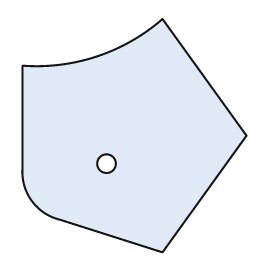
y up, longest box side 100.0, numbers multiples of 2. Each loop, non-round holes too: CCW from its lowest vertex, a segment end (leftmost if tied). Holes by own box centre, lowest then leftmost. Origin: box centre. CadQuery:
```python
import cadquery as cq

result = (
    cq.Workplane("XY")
    .moveTo(12.0, -50.0)
    .lineTo(48.0, 0.0)
    .lineTo(12.0, 50.0)
    .threePointArc((-16.0, 34.0), (-48.0, 30.0))
    .lineTo(-48.0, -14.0)
    .threePointArc((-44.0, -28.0), (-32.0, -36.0))
    .close()
    .moveTo(-12.0, -12.0)
    .circle(4.0)
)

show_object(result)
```